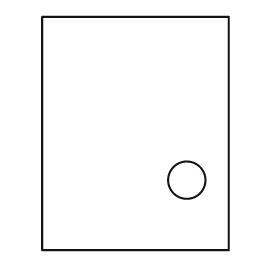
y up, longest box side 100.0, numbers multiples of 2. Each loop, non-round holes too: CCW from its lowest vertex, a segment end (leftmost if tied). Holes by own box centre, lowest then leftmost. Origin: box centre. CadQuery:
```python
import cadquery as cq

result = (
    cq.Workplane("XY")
    .moveTo(-40.0, -50.0)
    .lineTo(40.0, -50.0)
    .lineTo(40.0, 50.0)
    .lineTo(-40.0, 50.0)
    .close()
    .moveTo(22.0, -20.0)
    .circle(8.0)
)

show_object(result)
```